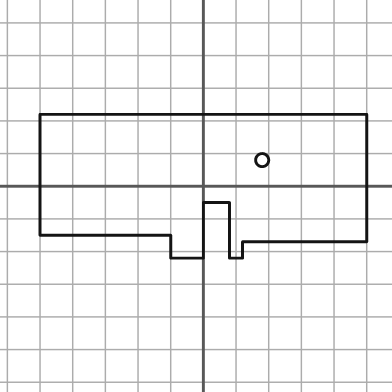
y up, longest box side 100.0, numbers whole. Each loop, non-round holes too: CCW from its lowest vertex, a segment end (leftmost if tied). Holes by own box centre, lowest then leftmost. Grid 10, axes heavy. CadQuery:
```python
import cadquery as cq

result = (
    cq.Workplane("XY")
    .moveTo(-10.0, -22.0)
    .lineTo(0.0, -22.0)
    .lineTo(0.0, -5.0)
    .lineTo(8.0, -5.0)
    .lineTo(8.0, -22.0)
    .lineTo(12.0, -22.0)
    .lineTo(12.0, -17.0)
    .lineTo(50.0, -17.0)
    .lineTo(50.0, 22.0)
    .lineTo(-50.0, 22.0)
    .lineTo(-50.0, -15.0)
    .lineTo(-10.0, -15.0)
    .close()
    .moveTo(18.0, 8.0)
    .circle(2.0)
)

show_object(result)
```